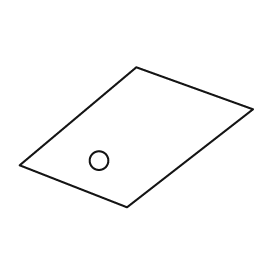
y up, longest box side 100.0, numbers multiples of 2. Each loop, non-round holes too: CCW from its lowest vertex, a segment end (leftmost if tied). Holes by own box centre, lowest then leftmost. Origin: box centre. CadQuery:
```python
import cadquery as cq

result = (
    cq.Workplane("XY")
    .moveTo(-4.0, -30.0)
    .lineTo(50.0, 12.0)
    .lineTo(0.0, 30.0)
    .lineTo(-50.0, -12.0)
    .close()
    .moveTo(-16.0, -10.0)
    .circle(4.0)
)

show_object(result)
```